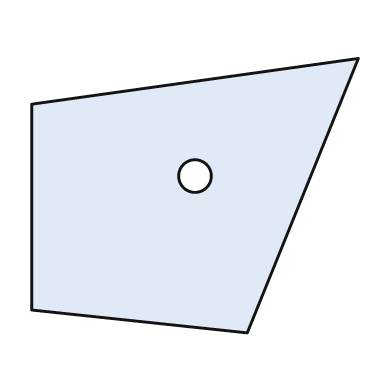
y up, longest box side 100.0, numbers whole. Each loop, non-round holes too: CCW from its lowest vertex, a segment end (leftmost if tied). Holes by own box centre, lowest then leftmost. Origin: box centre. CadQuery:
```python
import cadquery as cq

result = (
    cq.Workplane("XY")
    .moveTo(16.0, -42.0)
    .lineTo(50.0, 42.0)
    .lineTo(-50.0, 28.0)
    .lineTo(-50.0, -35.0)
    .close()
    .moveTo(0.0, 6.0)
    .circle(5.0)
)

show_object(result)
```